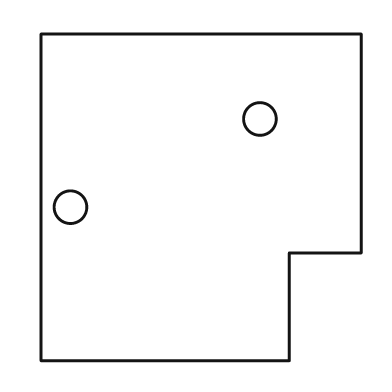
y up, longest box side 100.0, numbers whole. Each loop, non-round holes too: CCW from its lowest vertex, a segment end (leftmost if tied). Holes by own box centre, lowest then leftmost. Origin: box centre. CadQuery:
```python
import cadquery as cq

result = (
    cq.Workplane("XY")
    .moveTo(-49.0, -50.0)
    .lineTo(27.0, -50.0)
    .lineTo(27.0, -17.0)
    .lineTo(49.0, -17.0)
    .lineTo(49.0, 50.0)
    .lineTo(-49.0, 50.0)
    .close()
    .moveTo(-40.0, -3.0)
    .circle(5.0)
    .moveTo(18.0, 24.0)
    .circle(5.0)
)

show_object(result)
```